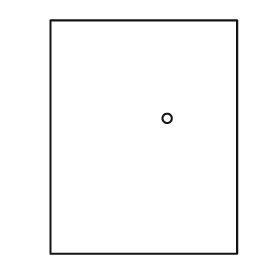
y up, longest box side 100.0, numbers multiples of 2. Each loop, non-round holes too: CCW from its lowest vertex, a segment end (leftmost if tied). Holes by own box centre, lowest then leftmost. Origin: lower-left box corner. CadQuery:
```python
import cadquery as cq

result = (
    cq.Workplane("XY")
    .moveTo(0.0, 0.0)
    .lineTo(80.0, 0.0)
    .lineTo(80.0, 100.0)
    .lineTo(0.0, 100.0)
    .close()
    .moveTo(50.0, 58.0)
    .circle(2.0)
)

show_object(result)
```